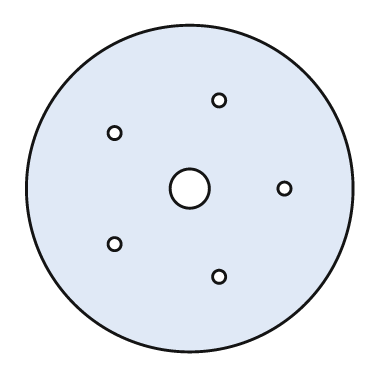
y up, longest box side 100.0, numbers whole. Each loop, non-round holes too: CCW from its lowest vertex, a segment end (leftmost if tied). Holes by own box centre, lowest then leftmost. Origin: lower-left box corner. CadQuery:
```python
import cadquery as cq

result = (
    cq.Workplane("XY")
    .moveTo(50.0, 50.0)
    .circle(50.0)
    .moveTo(59.0, 23.0)
    .circle(2.0)
    .moveTo(27.0, 33.0)
    .circle(2.0)
    .moveTo(50.0, 50.0)
    .circle(6.0)
    .moveTo(79.0, 50.0)
    .circle(2.0)
    .moveTo(27.0, 67.0)
    .circle(2.0)
    .moveTo(59.0, 77.0)
    .circle(2.0)
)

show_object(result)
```